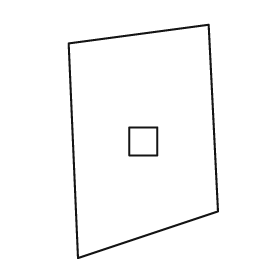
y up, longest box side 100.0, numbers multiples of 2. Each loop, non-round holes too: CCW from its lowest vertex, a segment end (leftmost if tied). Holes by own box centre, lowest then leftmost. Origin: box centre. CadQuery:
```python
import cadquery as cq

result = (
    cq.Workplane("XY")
    .moveTo(-28.0, -50.0)
    .lineTo(32.0, -30.0)
    .lineTo(28.0, 50.0)
    .lineTo(-32.0, 42.0)
    .close()
    .moveTo(-6.0, -6.0)
    .lineTo(6.0, -6.0)
    .lineTo(6.0, 6.0)
    .lineTo(-6.0, 6.0)
    .close()
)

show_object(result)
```